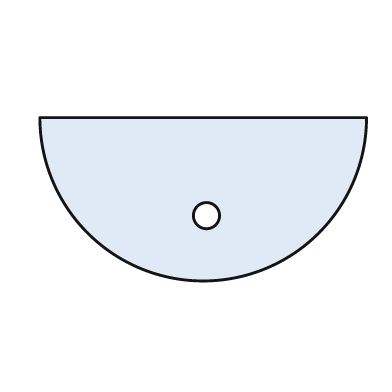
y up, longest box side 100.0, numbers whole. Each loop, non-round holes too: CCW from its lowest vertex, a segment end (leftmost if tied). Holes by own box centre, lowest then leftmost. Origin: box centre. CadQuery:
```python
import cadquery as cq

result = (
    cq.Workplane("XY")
    .moveTo(-50.0, 25.0)
    .threePointArc((0.0, -25.0), (50.0, 25.0))
    .close()
    .moveTo(1.0, -5.0)
    .circle(4.0)
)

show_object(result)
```